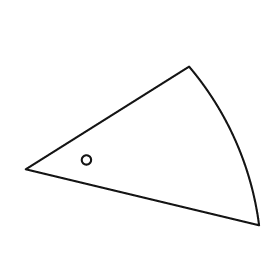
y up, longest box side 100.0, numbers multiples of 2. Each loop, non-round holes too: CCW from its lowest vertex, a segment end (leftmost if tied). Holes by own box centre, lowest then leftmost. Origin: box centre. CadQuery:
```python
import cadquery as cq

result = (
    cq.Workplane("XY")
    .moveTo(50.0, -34.0)
    .threePointArc((40.0, 2.0), (20.0, 34.0))
    .lineTo(-50.0, -10.0)
    .close()
    .moveTo(-24.0, -6.0)
    .circle(2.0)
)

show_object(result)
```